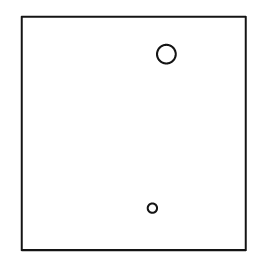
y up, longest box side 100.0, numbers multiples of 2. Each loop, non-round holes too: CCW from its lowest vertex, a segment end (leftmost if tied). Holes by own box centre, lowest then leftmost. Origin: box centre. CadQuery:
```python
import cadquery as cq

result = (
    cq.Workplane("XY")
    .moveTo(-48.0, -50.0)
    .lineTo(48.0, -50.0)
    .lineTo(48.0, 50.0)
    .lineTo(-48.0, 50.0)
    .close()
    .moveTo(8.0, -32.0)
    .circle(2.0)
    .moveTo(14.0, 34.0)
    .circle(4.0)
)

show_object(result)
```